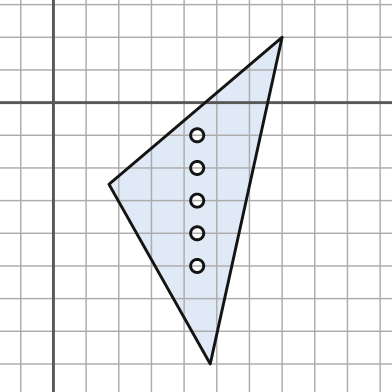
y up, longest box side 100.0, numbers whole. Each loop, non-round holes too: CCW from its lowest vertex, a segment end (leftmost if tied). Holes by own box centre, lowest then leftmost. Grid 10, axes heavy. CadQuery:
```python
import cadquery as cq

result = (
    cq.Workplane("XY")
    .moveTo(48.0, -80.0)
    .lineTo(70.0, 20.0)
    .lineTo(17.0, -25.0)
    .close()
    .moveTo(44.0, -50.0)
    .circle(2.0)
    .moveTo(44.0, -40.0)
    .circle(2.0)
    .moveTo(44.0, -30.0)
    .circle(2.0)
    .moveTo(44.0, -20.0)
    .circle(2.0)
    .moveTo(44.0, -10.0)
    .circle(2.0)
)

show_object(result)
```